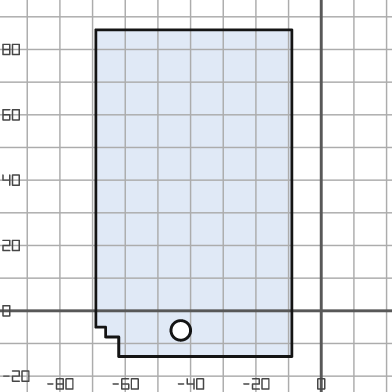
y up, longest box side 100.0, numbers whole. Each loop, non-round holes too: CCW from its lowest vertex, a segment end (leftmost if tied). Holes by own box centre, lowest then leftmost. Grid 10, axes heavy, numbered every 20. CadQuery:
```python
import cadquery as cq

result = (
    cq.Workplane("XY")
    .moveTo(-62.0, -14.0)
    .lineTo(-9.0, -14.0)
    .lineTo(-9.0, 86.0)
    .lineTo(-69.0, 86.0)
    .lineTo(-69.0, -5.0)
    .lineTo(-66.0, -5.0)
    .lineTo(-66.0, -8.0)
    .lineTo(-62.0, -8.0)
    .close()
    .moveTo(-43.0, -6.0)
    .circle(3.0)
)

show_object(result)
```